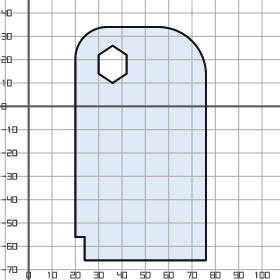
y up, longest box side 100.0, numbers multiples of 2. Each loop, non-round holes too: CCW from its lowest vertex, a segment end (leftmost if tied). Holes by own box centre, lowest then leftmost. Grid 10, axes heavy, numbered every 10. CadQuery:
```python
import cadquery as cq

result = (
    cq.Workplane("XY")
    .moveTo(24.0, -66.0)
    .lineTo(76.0, -66.0)
    .lineTo(76.0, 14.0)
    .threePointArc((70.0, 28.0), (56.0, 34.0))
    .lineTo(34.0, 34.0)
    .threePointArc((24.0, 30.0), (20.0, 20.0))
    .lineTo(20.0, -56.0)
    .lineTo(24.0, -56.0)
    .close()
    .moveTo(36.0, 10.0)
    .lineTo(42.0, 14.0)
    .lineTo(42.0, 22.0)
    .lineTo(36.0, 26.0)
    .lineTo(30.0, 22.0)
    .lineTo(30.0, 14.0)
    .close()
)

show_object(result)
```